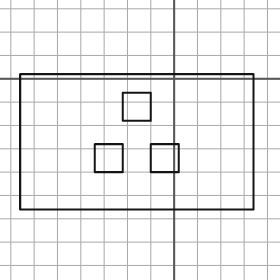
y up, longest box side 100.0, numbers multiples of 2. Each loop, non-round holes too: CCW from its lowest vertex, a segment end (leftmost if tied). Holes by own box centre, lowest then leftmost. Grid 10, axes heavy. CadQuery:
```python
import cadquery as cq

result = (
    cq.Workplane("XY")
    .moveTo(-66.0, -56.0)
    .lineTo(34.0, -56.0)
    .lineTo(34.0, 2.0)
    .lineTo(-66.0, 2.0)
    .close()
    .moveTo(-34.0, -40.0)
    .lineTo(-22.0, -40.0)
    .lineTo(-22.0, -28.0)
    .lineTo(-34.0, -28.0)
    .close()
    .moveTo(-10.0, -40.0)
    .lineTo(2.0, -40.0)
    .lineTo(2.0, -28.0)
    .lineTo(-10.0, -28.0)
    .close()
    .moveTo(-22.0, -18.0)
    .lineTo(-10.0, -18.0)
    .lineTo(-10.0, -6.0)
    .lineTo(-22.0, -6.0)
    .close()
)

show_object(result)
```